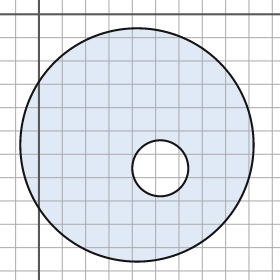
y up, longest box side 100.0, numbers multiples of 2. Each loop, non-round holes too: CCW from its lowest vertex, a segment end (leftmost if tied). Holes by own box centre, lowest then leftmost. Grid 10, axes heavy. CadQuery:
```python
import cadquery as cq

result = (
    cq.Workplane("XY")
    .moveTo(42.0, -56.0)
    .circle(50.0)
    .moveTo(52.0, -66.0)
    .circle(12.0)
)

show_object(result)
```